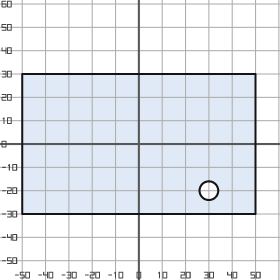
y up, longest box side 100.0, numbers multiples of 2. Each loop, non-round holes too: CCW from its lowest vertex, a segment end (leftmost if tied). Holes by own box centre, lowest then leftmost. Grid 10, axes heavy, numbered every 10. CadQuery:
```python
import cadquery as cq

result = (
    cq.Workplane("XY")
    .moveTo(-50.0, -30.0)
    .lineTo(50.0, -30.0)
    .lineTo(50.0, 30.0)
    .lineTo(-50.0, 30.0)
    .close()
    .moveTo(30.0, -20.0)
    .circle(4.0)
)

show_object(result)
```